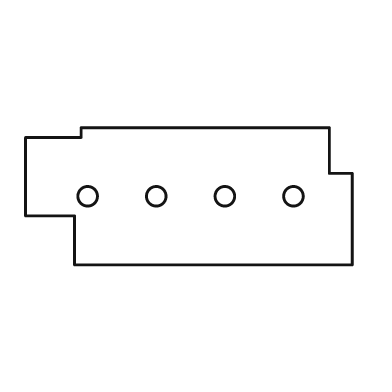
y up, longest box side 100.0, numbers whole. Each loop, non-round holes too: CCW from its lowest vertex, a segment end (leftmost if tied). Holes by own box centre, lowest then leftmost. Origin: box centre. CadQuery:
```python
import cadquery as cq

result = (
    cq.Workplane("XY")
    .moveTo(-35.0, -21.0)
    .lineTo(50.0, -21.0)
    .lineTo(50.0, 7.0)
    .lineTo(43.0, 7.0)
    .lineTo(43.0, 21.0)
    .lineTo(-33.0, 21.0)
    .lineTo(-33.0, 18.0)
    .lineTo(-50.0, 18.0)
    .lineTo(-50.0, -6.0)
    .lineTo(-35.0, -6.0)
    .close()
    .moveTo(-31.0, 0.0)
    .circle(3.0)
    .moveTo(-10.0, 0.0)
    .circle(3.0)
    .moveTo(11.0, 0.0)
    .circle(3.0)
    .moveTo(32.0, 0.0)
    .circle(3.0)
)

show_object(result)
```